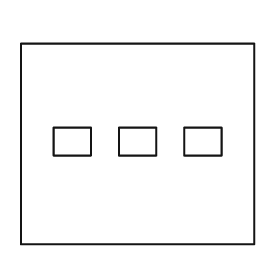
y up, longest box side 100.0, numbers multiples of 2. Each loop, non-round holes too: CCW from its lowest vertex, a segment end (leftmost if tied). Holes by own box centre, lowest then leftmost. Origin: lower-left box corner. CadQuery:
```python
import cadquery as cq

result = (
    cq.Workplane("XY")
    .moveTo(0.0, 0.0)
    .lineTo(100.0, 0.0)
    .lineTo(100.0, 86.0)
    .lineTo(0.0, 86.0)
    .close()
    .moveTo(14.0, 38.0)
    .lineTo(30.0, 38.0)
    .lineTo(30.0, 50.0)
    .lineTo(14.0, 50.0)
    .close()
    .moveTo(42.0, 38.0)
    .lineTo(58.0, 38.0)
    .lineTo(58.0, 50.0)
    .lineTo(42.0, 50.0)
    .close()
    .moveTo(70.0, 38.0)
    .lineTo(86.0, 38.0)
    .lineTo(86.0, 50.0)
    .lineTo(70.0, 50.0)
    .close()
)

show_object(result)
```